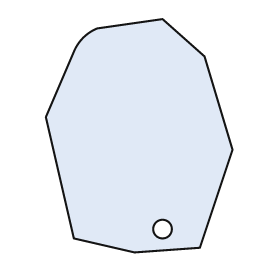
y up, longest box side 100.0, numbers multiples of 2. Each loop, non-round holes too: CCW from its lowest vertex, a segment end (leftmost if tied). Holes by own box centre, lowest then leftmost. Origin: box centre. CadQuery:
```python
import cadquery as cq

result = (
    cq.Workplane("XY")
    .moveTo(-2.0, -50.0)
    .lineTo(26.0, -48.0)
    .lineTo(40.0, -6.0)
    .lineTo(28.0, 34.0)
    .lineTo(10.0, 50.0)
    .lineTo(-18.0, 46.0)
    .threePointArc((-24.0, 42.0), (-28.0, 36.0))
    .lineTo(-40.0, 8.0)
    .lineTo(-28.0, -44.0)
    .close()
    .moveTo(10.0, -40.0)
    .circle(4.0)
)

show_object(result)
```